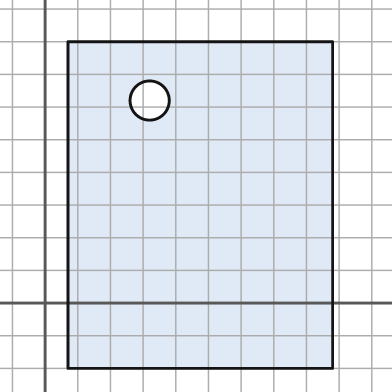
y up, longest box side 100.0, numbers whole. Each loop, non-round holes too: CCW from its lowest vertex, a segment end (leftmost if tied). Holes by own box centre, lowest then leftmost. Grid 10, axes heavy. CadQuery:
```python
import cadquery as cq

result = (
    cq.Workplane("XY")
    .moveTo(7.0, -20.0)
    .lineTo(88.0, -20.0)
    .lineTo(88.0, 80.0)
    .lineTo(7.0, 80.0)
    .close()
    .moveTo(32.0, 62.0)
    .circle(6.0)
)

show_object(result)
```